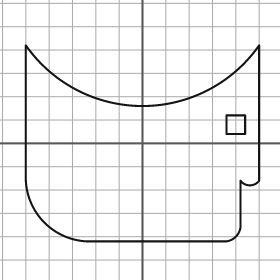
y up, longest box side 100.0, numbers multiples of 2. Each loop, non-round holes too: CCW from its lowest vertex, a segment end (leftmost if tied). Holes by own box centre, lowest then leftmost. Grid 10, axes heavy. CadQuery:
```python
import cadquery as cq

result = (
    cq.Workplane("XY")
    .moveTo(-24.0, -42.0)
    .lineTo(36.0, -42.0)
    .threePointArc((40.0, -40.0), (42.0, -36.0))
    .lineTo(42.0, -16.0)
    .threePointArc((46.0, -18.0), (50.0, -16.0))
    .lineTo(50.0, 42.0)
    .threePointArc((0.0, 16.0), (-50.0, 42.0))
    .lineTo(-50.0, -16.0)
    .threePointArc((-42.0, -34.0), (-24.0, -42.0))
    .close()
    .moveTo(36.0, 4.0)
    .lineTo(44.0, 4.0)
    .lineTo(44.0, 12.0)
    .lineTo(36.0, 12.0)
    .close()
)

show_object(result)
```